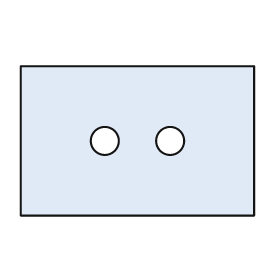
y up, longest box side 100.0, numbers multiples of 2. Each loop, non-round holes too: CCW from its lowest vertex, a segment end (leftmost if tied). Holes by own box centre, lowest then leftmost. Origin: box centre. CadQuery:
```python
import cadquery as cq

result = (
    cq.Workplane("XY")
    .moveTo(-50.0, -32.0)
    .lineTo(50.0, -32.0)
    .lineTo(50.0, 32.0)
    .lineTo(-50.0, 32.0)
    .close()
    .moveTo(-14.0, 0.0)
    .circle(6.0)
    .moveTo(14.0, 0.0)
    .circle(6.0)
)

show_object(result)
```